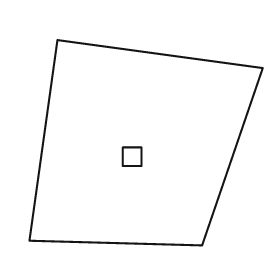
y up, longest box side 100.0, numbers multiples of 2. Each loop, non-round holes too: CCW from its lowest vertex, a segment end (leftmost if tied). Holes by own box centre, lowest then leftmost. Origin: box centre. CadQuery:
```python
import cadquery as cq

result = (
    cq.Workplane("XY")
    .moveTo(24.0, -44.0)
    .lineTo(50.0, 32.0)
    .lineTo(-38.0, 44.0)
    .lineTo(-50.0, -42.0)
    .close()
    .moveTo(-10.0, -10.0)
    .lineTo(-2.0, -10.0)
    .lineTo(-2.0, -2.0)
    .lineTo(-10.0, -2.0)
    .close()
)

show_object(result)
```